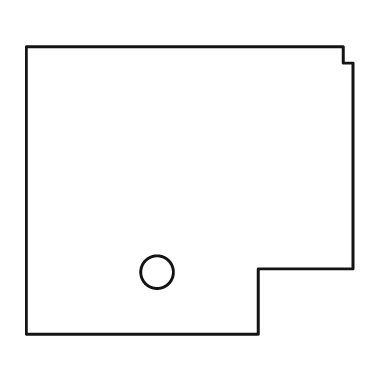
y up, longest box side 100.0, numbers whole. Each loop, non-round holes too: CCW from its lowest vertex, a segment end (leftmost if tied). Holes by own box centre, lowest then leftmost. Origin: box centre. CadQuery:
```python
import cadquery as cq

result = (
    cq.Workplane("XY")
    .moveTo(-50.0, -44.0)
    .lineTo(21.0, -44.0)
    .lineTo(21.0, -24.0)
    .lineTo(50.0, -24.0)
    .lineTo(50.0, 39.0)
    .lineTo(47.0, 39.0)
    .lineTo(47.0, 44.0)
    .lineTo(-50.0, 44.0)
    .close()
    .moveTo(-10.0, -25.0)
    .circle(5.0)
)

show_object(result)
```